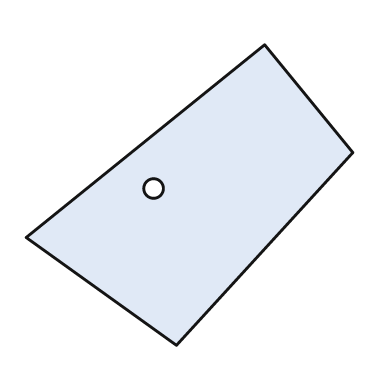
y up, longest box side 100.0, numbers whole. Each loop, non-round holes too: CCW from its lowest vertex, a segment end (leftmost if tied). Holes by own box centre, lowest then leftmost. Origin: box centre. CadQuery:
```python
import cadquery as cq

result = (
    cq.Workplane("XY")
    .moveTo(-4.0, -46.0)
    .lineTo(50.0, 13.0)
    .lineTo(23.0, 46.0)
    .lineTo(-50.0, -13.0)
    .close()
    .moveTo(-11.0, 2.0)
    .circle(3.0)
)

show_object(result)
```